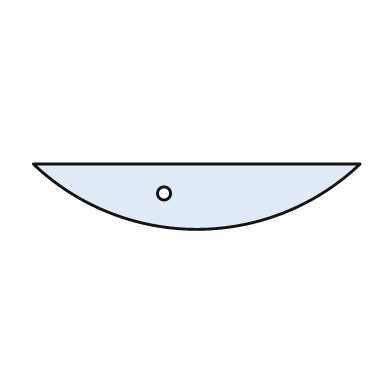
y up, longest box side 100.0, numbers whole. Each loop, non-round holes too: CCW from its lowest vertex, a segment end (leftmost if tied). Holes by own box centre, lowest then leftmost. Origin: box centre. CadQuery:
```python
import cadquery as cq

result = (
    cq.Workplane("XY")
    .moveTo(-50.0, 10.0)
    .threePointArc((0.0, -10.0), (50.0, 10.0))
    .close()
    .moveTo(-10.0, 1.0)
    .circle(2.0)
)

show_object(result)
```